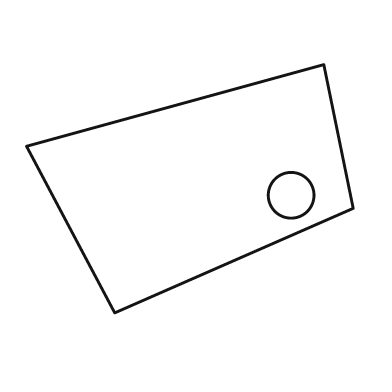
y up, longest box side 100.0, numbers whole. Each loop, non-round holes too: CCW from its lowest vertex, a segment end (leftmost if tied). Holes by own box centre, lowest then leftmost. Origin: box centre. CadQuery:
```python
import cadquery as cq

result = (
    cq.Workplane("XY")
    .moveTo(-23.0, -38.0)
    .lineTo(50.0, -6.0)
    .lineTo(41.0, 38.0)
    .lineTo(-50.0, 13.0)
    .close()
    .moveTo(31.0, -2.0)
    .circle(7.0)
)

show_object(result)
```